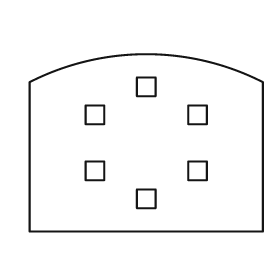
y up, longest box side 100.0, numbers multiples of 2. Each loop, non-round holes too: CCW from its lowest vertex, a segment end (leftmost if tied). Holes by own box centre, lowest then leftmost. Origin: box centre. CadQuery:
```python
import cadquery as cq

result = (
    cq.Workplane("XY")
    .moveTo(-50.0, -38.0)
    .lineTo(50.0, -38.0)
    .lineTo(50.0, 26.0)
    .threePointArc((0.0, 38.0), (-50.0, 26.0))
    .close()
    .moveTo(-4.0, -28.0)
    .lineTo(4.0, -28.0)
    .lineTo(4.0, -20.0)
    .lineTo(-4.0, -20.0)
    .close()
    .moveTo(-26.0, -16.0)
    .lineTo(-18.0, -16.0)
    .lineTo(-18.0, -8.0)
    .lineTo(-26.0, -8.0)
    .close()
    .moveTo(18.0, -16.0)
    .lineTo(26.0, -16.0)
    .lineTo(26.0, -8.0)
    .lineTo(18.0, -8.0)
    .close()
    .moveTo(-26.0, 8.0)
    .lineTo(-18.0, 8.0)
    .lineTo(-18.0, 16.0)
    .lineTo(-26.0, 16.0)
    .close()
    .moveTo(18.0, 8.0)
    .lineTo(26.0, 8.0)
    .lineTo(26.0, 16.0)
    .lineTo(18.0, 16.0)
    .close()
    .moveTo(-4.0, 20.0)
    .lineTo(4.0, 20.0)
    .lineTo(4.0, 28.0)
    .lineTo(-4.0, 28.0)
    .close()
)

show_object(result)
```